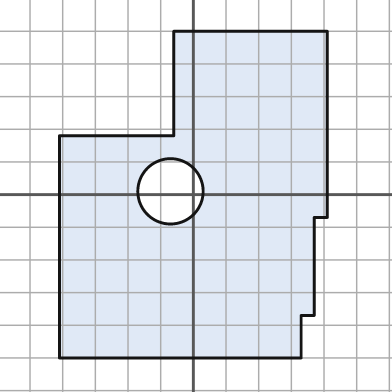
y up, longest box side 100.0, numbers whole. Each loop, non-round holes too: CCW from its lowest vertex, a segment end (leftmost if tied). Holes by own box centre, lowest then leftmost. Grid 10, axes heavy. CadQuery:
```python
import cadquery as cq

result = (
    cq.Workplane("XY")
    .moveTo(-41.0, -50.0)
    .lineTo(33.0, -50.0)
    .lineTo(33.0, -37.0)
    .lineTo(37.0, -37.0)
    .lineTo(37.0, -7.0)
    .lineTo(41.0, -7.0)
    .lineTo(41.0, 50.0)
    .lineTo(-6.0, 50.0)
    .lineTo(-6.0, 18.0)
    .lineTo(-41.0, 18.0)
    .close()
    .moveTo(-7.0, 1.0)
    .circle(10.0)
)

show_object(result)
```